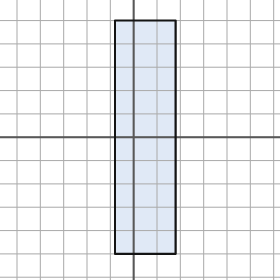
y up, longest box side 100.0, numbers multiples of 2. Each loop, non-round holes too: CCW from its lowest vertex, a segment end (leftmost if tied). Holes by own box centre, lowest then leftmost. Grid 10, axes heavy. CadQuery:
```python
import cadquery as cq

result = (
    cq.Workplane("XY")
    .moveTo(-8.0, -50.0)
    .lineTo(18.0, -50.0)
    .lineTo(18.0, 50.0)
    .lineTo(-8.0, 50.0)
    .close()
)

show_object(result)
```